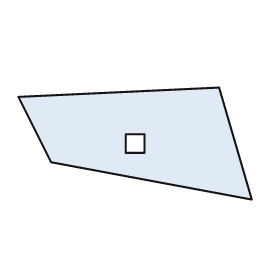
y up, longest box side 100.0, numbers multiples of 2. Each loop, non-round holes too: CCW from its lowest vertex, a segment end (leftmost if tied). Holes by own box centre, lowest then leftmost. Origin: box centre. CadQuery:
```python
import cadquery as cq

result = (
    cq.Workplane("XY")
    .moveTo(50.0, -24.0)
    .lineTo(36.0, 24.0)
    .lineTo(-50.0, 20.0)
    .lineTo(-36.0, -8.0)
    .close()
    .moveTo(-4.0, -4.0)
    .lineTo(4.0, -4.0)
    .lineTo(4.0, 4.0)
    .lineTo(-4.0, 4.0)
    .close()
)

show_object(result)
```